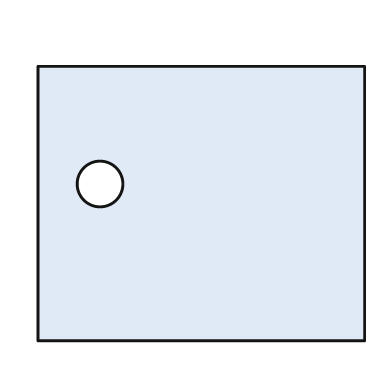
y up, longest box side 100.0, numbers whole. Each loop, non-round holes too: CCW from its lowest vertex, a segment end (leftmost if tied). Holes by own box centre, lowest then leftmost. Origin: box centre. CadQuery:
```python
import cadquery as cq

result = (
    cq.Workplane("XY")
    .moveTo(-50.0, -42.0)
    .lineTo(50.0, -42.0)
    .lineTo(50.0, 42.0)
    .lineTo(-50.0, 42.0)
    .close()
    .moveTo(-31.0, 6.0)
    .circle(7.0)
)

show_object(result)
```